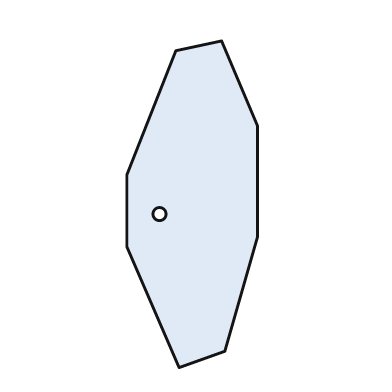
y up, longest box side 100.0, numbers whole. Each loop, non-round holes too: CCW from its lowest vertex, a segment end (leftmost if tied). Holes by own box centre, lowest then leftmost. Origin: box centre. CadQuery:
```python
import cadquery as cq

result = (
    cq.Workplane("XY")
    .moveTo(-4.0, -50.0)
    .lineTo(10.0, -45.0)
    .lineTo(20.0, -10.0)
    .lineTo(20.0, 24.0)
    .lineTo(9.0, 50.0)
    .lineTo(-5.0, 47.0)
    .lineTo(-20.0, 9.0)
    .lineTo(-20.0, -13.0)
    .close()
    .moveTo(-10.0, -3.0)
    .circle(2.0)
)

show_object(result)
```